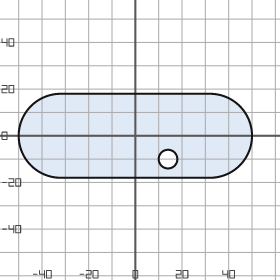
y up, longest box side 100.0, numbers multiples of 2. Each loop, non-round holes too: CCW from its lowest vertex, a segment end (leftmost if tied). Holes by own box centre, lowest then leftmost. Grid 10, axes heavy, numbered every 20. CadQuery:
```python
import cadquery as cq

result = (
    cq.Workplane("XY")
    .moveTo(-32.0, -18.0)
    .lineTo(32.0, -18.0)
    .threePointArc((50.0, 0.0), (32.0, 18.0))
    .lineTo(-32.0, 18.0)
    .threePointArc((-50.0, 0.0), (-32.0, -18.0))
    .close()
    .moveTo(14.0, -10.0)
    .circle(4.0)
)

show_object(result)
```